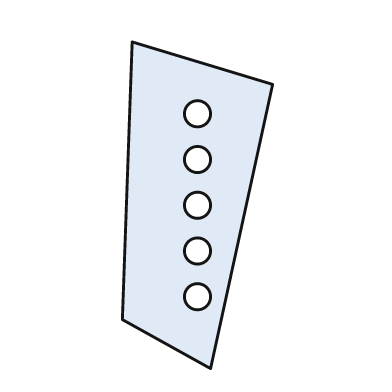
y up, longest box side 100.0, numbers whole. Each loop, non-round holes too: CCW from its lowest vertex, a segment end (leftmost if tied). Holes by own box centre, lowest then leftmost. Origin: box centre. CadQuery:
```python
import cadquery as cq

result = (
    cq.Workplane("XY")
    .moveTo(4.0, -50.0)
    .lineTo(23.0, 37.0)
    .lineTo(-20.0, 50.0)
    .lineTo(-23.0, -35.0)
    .close()
    .moveTo(0.0, -28.0)
    .circle(4.0)
    .moveTo(0.0, -14.0)
    .circle(4.0)
    .moveTo(0.0, 0.0)
    .circle(4.0)
    .moveTo(0.0, 14.0)
    .circle(4.0)
    .moveTo(0.0, 28.0)
    .circle(4.0)
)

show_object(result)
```